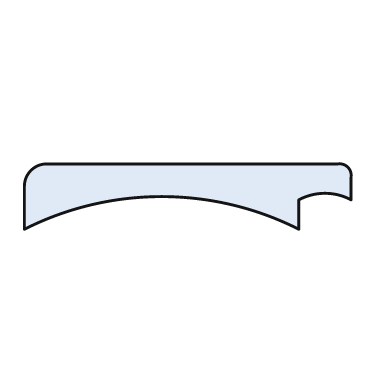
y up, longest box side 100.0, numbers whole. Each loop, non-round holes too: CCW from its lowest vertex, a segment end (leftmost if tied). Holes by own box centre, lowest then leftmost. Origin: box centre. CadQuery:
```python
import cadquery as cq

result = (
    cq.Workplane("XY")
    .moveTo(-50.0, -10.0)
    .threePointArc((-8.0, 0.0), (34.0, -10.0))
    .lineTo(34.0, -1.0)
    .threePointArc((42.0, 1.0), (50.0, -1.0))
    .lineTo(50.0, 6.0)
    .threePointArc((49.0, 9.0), (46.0, 10.0))
    .lineTo(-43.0, 10.0)
    .threePointArc((-48.0, 8.0), (-50.0, 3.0))
    .close()
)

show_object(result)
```